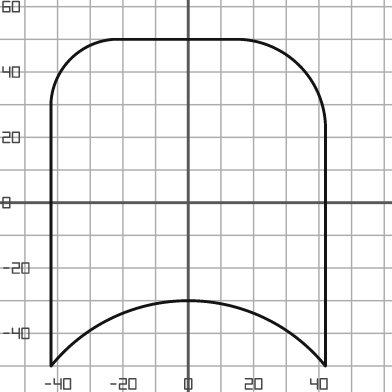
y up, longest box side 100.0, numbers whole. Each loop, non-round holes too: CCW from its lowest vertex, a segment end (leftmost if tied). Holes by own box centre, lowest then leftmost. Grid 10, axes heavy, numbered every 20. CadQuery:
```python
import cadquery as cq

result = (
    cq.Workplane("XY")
    .moveTo(-42.0, -50.0)
    .threePointArc((0.0, -30.0), (42.0, -50.0))
    .lineTo(42.0, 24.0)
    .threePointArc((34.0, 42.0), (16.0, 50.0))
    .lineTo(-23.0, 50.0)
    .threePointArc((-36.0, 44.0), (-42.0, 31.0))
    .close()
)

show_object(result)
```